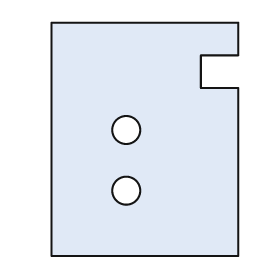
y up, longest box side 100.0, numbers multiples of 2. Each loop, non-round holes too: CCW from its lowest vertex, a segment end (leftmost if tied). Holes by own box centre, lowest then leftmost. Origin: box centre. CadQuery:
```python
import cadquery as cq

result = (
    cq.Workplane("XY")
    .moveTo(-40.0, -50.0)
    .lineTo(40.0, -50.0)
    .lineTo(40.0, 22.0)
    .lineTo(24.0, 22.0)
    .lineTo(24.0, 36.0)
    .lineTo(40.0, 36.0)
    .lineTo(40.0, 50.0)
    .lineTo(-40.0, 50.0)
    .close()
    .moveTo(-8.0, -22.0)
    .circle(6.0)
    .moveTo(-8.0, 4.0)
    .circle(6.0)
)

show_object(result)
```